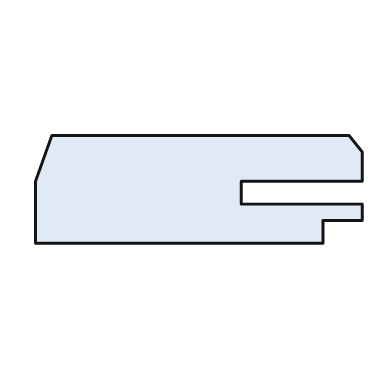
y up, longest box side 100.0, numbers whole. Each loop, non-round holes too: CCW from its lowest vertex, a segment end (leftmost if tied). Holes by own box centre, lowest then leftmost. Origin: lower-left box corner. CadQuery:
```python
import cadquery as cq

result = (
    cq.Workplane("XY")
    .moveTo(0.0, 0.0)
    .lineTo(88.0, 0.0)
    .lineTo(88.0, 7.0)
    .lineTo(100.0, 7.0)
    .lineTo(100.0, 12.0)
    .lineTo(63.0, 12.0)
    .lineTo(63.0, 19.0)
    .lineTo(100.0, 19.0)
    .lineTo(100.0, 28.0)
    .lineTo(96.0, 33.0)
    .lineTo(5.0, 33.0)
    .lineTo(0.0, 19.0)
    .close()
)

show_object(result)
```